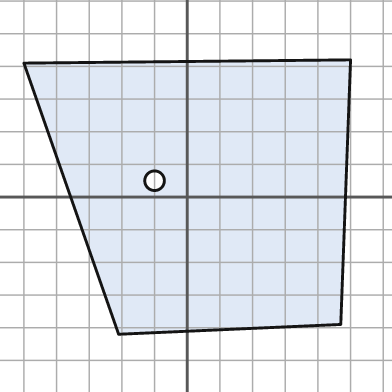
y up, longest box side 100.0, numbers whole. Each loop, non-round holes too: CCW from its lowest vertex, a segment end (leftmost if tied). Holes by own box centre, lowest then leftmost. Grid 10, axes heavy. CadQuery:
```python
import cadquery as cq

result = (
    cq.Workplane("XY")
    .moveTo(-21.0, -42.0)
    .lineTo(47.0, -39.0)
    .lineTo(50.0, 42.0)
    .lineTo(-50.0, 41.0)
    .close()
    .moveTo(-10.0, 5.0)
    .circle(3.0)
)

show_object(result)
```